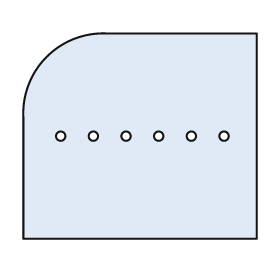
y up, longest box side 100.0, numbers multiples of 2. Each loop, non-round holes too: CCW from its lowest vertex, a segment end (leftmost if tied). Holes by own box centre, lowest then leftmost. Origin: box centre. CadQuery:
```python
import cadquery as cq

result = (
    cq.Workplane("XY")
    .moveTo(-50.0, -44.0)
    .lineTo(50.0, -44.0)
    .lineTo(50.0, 44.0)
    .lineTo(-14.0, 44.0)
    .threePointArc((-40.0, 34.0), (-50.0, 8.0))
    .close()
    .moveTo(-34.0, 0.0)
    .circle(2.0)
    .moveTo(-20.0, 0.0)
    .circle(2.0)
    .moveTo(-6.0, 0.0)
    .circle(2.0)
    .moveTo(8.0, 0.0)
    .circle(2.0)
    .moveTo(22.0, 0.0)
    .circle(2.0)
    .moveTo(36.0, 0.0)
    .circle(2.0)
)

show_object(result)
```